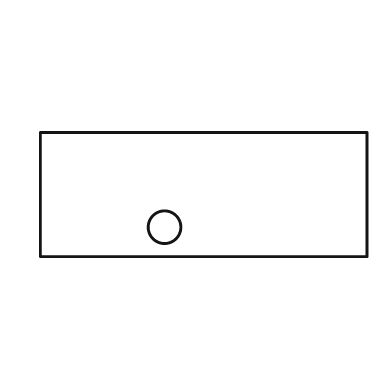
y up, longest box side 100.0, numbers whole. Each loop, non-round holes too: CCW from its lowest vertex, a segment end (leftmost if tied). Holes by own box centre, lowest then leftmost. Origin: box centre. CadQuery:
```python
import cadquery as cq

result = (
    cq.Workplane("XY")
    .moveTo(-50.0, -19.0)
    .lineTo(50.0, -19.0)
    .lineTo(50.0, 19.0)
    .lineTo(-50.0, 19.0)
    .close()
    .moveTo(-12.0, -10.0)
    .circle(5.0)
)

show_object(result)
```